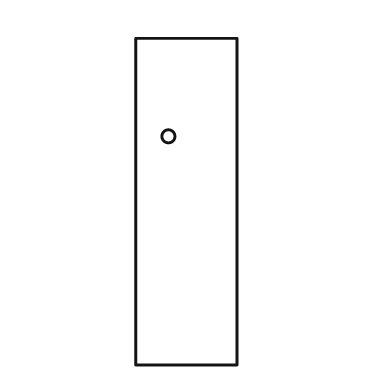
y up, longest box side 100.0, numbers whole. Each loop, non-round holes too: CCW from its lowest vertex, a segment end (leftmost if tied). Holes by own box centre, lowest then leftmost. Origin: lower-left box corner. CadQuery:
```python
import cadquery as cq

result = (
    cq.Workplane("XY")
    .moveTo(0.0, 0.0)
    .lineTo(31.0, 0.0)
    .lineTo(31.0, 100.0)
    .lineTo(0.0, 100.0)
    .close()
    .moveTo(10.0, 70.0)
    .circle(2.0)
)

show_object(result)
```